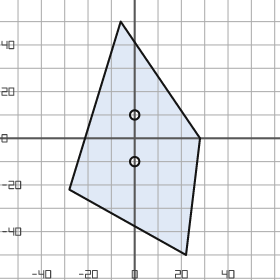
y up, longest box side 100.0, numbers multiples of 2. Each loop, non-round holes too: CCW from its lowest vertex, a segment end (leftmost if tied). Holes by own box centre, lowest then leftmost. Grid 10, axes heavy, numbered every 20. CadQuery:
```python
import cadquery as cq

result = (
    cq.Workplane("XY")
    .moveTo(22.0, -50.0)
    .lineTo(28.0, 0.0)
    .lineTo(-6.0, 50.0)
    .lineTo(-28.0, -22.0)
    .close()
    .moveTo(0.0, -10.0)
    .circle(2.0)
    .moveTo(0.0, 10.0)
    .circle(2.0)
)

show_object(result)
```